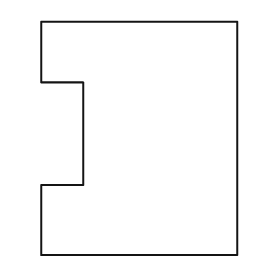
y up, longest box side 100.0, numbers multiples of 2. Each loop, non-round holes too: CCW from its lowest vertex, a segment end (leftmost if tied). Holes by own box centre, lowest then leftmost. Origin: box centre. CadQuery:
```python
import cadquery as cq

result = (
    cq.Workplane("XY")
    .moveTo(-42.0, -50.0)
    .lineTo(42.0, -50.0)
    .lineTo(42.0, 50.0)
    .lineTo(-42.0, 50.0)
    .lineTo(-42.0, 24.0)
    .lineTo(-24.0, 24.0)
    .lineTo(-24.0, -20.0)
    .lineTo(-42.0, -20.0)
    .close()
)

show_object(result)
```